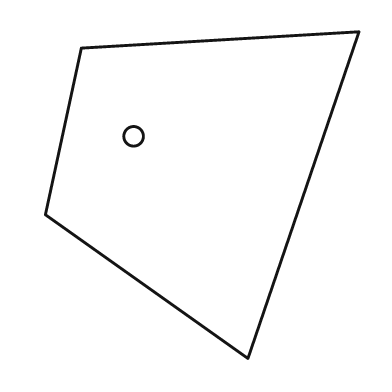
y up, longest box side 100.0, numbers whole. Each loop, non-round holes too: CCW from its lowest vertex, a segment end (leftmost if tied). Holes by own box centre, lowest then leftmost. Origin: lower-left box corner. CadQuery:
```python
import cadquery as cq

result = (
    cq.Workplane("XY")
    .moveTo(62.0, 0.0)
    .lineTo(96.0, 100.0)
    .lineTo(11.0, 95.0)
    .lineTo(0.0, 44.0)
    .close()
    .moveTo(27.0, 68.0)
    .circle(3.0)
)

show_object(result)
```